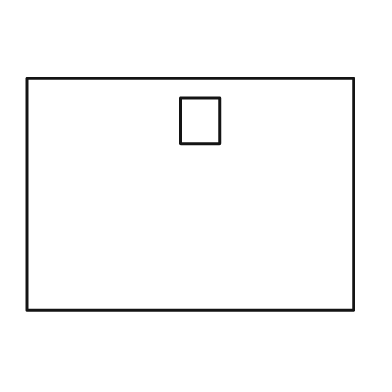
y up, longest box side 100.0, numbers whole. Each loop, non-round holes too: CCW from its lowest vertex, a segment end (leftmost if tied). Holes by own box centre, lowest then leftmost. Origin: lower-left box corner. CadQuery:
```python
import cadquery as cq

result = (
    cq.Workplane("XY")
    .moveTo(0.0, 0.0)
    .lineTo(100.0, 0.0)
    .lineTo(100.0, 71.0)
    .lineTo(0.0, 71.0)
    .close()
    .moveTo(47.0, 51.0)
    .lineTo(59.0, 51.0)
    .lineTo(59.0, 65.0)
    .lineTo(47.0, 65.0)
    .close()
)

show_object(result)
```